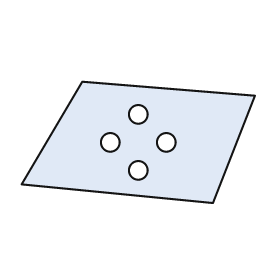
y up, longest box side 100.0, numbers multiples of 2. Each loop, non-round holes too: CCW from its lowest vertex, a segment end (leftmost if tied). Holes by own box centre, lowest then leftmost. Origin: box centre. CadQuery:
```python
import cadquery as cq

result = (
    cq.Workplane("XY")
    .moveTo(32.0, -26.0)
    .lineTo(50.0, 20.0)
    .lineTo(-24.0, 26.0)
    .lineTo(-50.0, -18.0)
    .close()
    .moveTo(0.0, -12.0)
    .circle(4.0)
    .moveTo(-12.0, 0.0)
    .circle(4.0)
    .moveTo(12.0, 0.0)
    .circle(4.0)
    .moveTo(0.0, 12.0)
    .circle(4.0)
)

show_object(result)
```